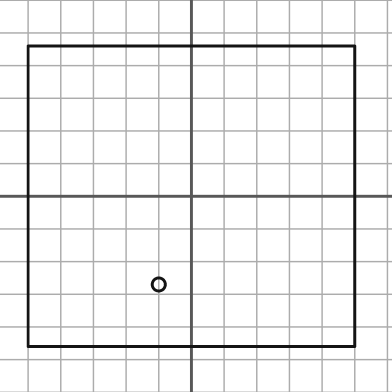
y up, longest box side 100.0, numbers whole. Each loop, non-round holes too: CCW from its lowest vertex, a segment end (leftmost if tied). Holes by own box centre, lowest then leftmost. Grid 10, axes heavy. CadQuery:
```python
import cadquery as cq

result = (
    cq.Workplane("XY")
    .moveTo(-50.0, -46.0)
    .lineTo(50.0, -46.0)
    .lineTo(50.0, 46.0)
    .lineTo(-50.0, 46.0)
    .close()
    .moveTo(-10.0, -27.0)
    .circle(2.0)
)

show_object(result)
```